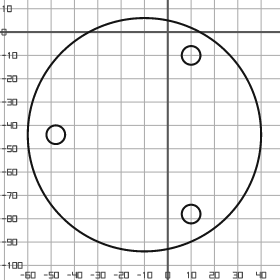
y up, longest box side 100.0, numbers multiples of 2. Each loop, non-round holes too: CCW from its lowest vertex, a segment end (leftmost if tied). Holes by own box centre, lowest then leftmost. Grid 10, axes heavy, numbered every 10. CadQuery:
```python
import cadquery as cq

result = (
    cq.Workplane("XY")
    .moveTo(-10.0, -44.0)
    .circle(50.0)
    .moveTo(10.0, -78.0)
    .circle(4.0)
    .moveTo(-48.0, -44.0)
    .circle(4.0)
    .moveTo(10.0, -10.0)
    .circle(4.0)
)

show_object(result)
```